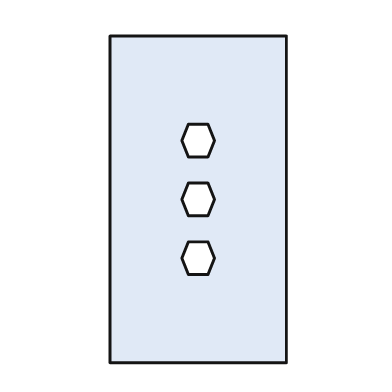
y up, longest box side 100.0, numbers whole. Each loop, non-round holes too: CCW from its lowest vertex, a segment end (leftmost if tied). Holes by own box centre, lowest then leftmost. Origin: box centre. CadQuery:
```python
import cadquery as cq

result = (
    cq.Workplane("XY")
    .moveTo(-27.0, -50.0)
    .lineTo(27.0, -50.0)
    .lineTo(27.0, 50.0)
    .lineTo(-27.0, 50.0)
    .close()
    .moveTo(-3.0, -23.0)
    .lineTo(3.0, -23.0)
    .lineTo(5.0, -18.0)
    .lineTo(3.0, -13.0)
    .lineTo(-3.0, -13.0)
    .lineTo(-5.0, -18.0)
    .close()
    .moveTo(-3.0, -5.0)
    .lineTo(3.0, -5.0)
    .lineTo(5.0, 0.0)
    .lineTo(3.0, 5.0)
    .lineTo(-3.0, 5.0)
    .lineTo(-5.0, 0.0)
    .close()
    .moveTo(-3.0, 13.0)
    .lineTo(3.0, 13.0)
    .lineTo(5.0, 18.0)
    .lineTo(3.0, 23.0)
    .lineTo(-3.0, 23.0)
    .lineTo(-5.0, 18.0)
    .close()
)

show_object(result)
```